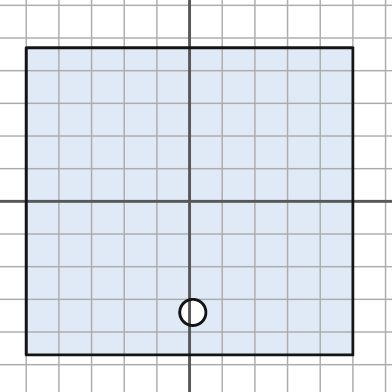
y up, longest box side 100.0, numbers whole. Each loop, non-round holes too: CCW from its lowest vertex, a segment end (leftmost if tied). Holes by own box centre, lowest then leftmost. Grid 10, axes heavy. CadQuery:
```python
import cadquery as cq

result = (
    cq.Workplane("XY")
    .moveTo(-50.0, -47.0)
    .lineTo(50.0, -47.0)
    .lineTo(50.0, 47.0)
    .lineTo(-50.0, 47.0)
    .close()
    .moveTo(1.0, -34.0)
    .circle(4.0)
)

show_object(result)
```